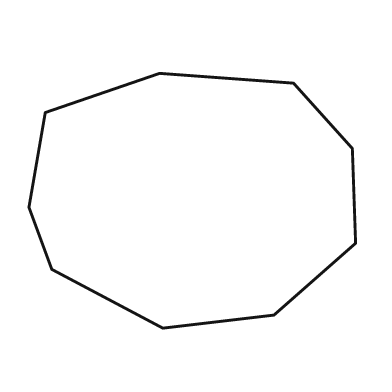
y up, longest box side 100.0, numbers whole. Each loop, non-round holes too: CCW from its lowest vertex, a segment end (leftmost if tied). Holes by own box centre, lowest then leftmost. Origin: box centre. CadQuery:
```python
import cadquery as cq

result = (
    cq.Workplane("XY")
    .moveTo(-9.0, -39.0)
    .lineTo(25.0, -35.0)
    .lineTo(50.0, -13.0)
    .lineTo(49.0, 16.0)
    .lineTo(31.0, 36.0)
    .lineTo(-10.0, 39.0)
    .lineTo(-45.0, 27.0)
    .lineTo(-50.0, -2.0)
    .lineTo(-43.0, -21.0)
    .close()
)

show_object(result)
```